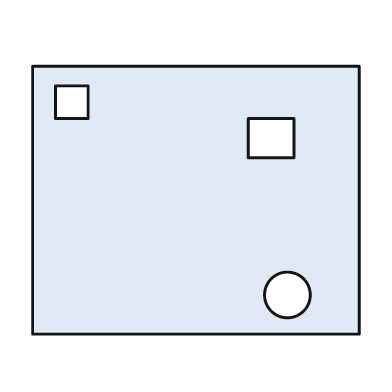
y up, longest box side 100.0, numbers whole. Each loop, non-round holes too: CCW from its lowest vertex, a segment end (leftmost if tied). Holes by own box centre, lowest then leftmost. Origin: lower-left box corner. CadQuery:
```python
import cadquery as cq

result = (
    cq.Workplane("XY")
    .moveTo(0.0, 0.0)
    .lineTo(100.0, 0.0)
    .lineTo(100.0, 82.0)
    .lineTo(0.0, 82.0)
    .close()
    .moveTo(78.0, 12.0)
    .circle(7.0)
    .moveTo(66.0, 54.0)
    .lineTo(80.0, 54.0)
    .lineTo(80.0, 66.0)
    .lineTo(66.0, 66.0)
    .close()
    .moveTo(7.0, 66.0)
    .lineTo(17.0, 66.0)
    .lineTo(17.0, 76.0)
    .lineTo(7.0, 76.0)
    .close()
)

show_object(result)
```